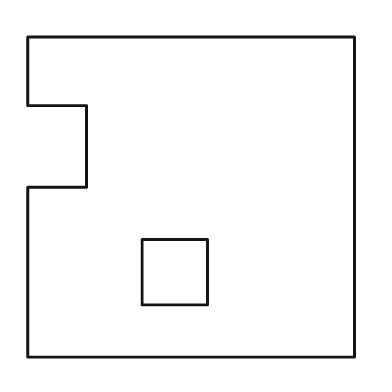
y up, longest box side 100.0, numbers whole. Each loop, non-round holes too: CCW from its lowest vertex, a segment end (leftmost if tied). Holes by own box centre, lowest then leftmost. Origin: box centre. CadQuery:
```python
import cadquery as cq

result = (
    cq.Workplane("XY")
    .moveTo(-50.0, -49.0)
    .lineTo(50.0, -49.0)
    .lineTo(50.0, 49.0)
    .lineTo(-50.0, 49.0)
    .lineTo(-50.0, 28.0)
    .lineTo(-32.0, 28.0)
    .lineTo(-32.0, 3.0)
    .lineTo(-50.0, 3.0)
    .close()
    .moveTo(-15.0, -33.0)
    .lineTo(5.0, -33.0)
    .lineTo(5.0, -13.0)
    .lineTo(-15.0, -13.0)
    .close()
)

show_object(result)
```